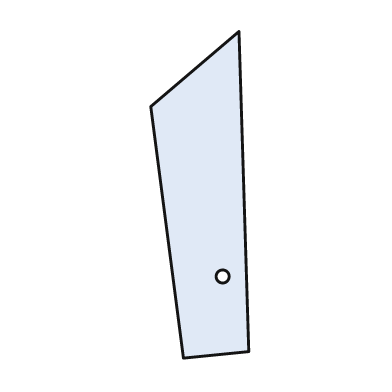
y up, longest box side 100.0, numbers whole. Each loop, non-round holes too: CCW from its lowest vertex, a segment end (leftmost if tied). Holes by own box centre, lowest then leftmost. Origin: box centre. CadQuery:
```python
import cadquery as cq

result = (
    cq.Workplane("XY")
    .moveTo(-5.0, -50.0)
    .lineTo(15.0, -48.0)
    .lineTo(12.0, 50.0)
    .lineTo(-15.0, 27.0)
    .close()
    .moveTo(7.0, -25.0)
    .circle(2.0)
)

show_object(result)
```